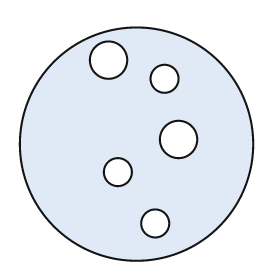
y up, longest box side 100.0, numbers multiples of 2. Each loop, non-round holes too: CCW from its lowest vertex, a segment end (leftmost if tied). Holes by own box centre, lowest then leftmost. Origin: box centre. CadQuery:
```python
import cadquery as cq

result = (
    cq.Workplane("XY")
    .moveTo(0.0, 0.0)
    .circle(50.0)
    .moveTo(8.0, -34.0)
    .circle(6.0)
    .moveTo(-8.0, -12.0)
    .circle(6.0)
    .moveTo(18.0, 2.0)
    .circle(8.0)
    .moveTo(12.0, 28.0)
    .circle(6.0)
    .moveTo(-12.0, 36.0)
    .circle(8.0)
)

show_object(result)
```